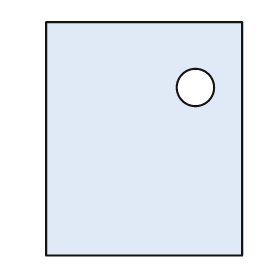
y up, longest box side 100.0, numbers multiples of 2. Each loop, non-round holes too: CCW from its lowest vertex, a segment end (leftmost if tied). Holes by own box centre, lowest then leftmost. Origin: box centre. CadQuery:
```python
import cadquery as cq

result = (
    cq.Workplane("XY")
    .moveTo(-42.0, -50.0)
    .lineTo(42.0, -50.0)
    .lineTo(42.0, 50.0)
    .lineTo(-42.0, 50.0)
    .close()
    .moveTo(22.0, 22.0)
    .circle(8.0)
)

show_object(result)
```